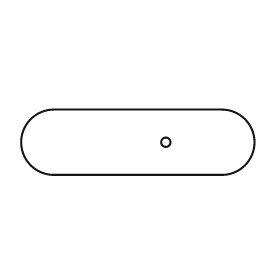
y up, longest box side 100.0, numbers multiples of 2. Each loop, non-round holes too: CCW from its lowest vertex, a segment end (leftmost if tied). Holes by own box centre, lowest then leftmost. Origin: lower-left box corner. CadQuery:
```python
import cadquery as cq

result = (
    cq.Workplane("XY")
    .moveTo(14.0, 0.0)
    .lineTo(86.0, 0.0)
    .threePointArc((100.0, 14.0), (86.0, 28.0))
    .lineTo(14.0, 28.0)
    .threePointArc((0.0, 14.0), (14.0, 0.0))
    .close()
    .moveTo(62.0, 14.0)
    .circle(2.0)
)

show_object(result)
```